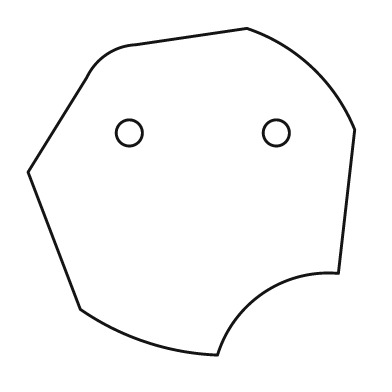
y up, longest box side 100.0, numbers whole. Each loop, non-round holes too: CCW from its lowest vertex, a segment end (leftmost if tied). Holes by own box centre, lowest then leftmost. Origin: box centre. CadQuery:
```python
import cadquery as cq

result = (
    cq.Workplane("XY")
    .moveTo(8.0, -50.0)
    .threePointArc((22.0, -31.0), (45.0, -25.0))
    .lineTo(50.0, 19.0)
    .threePointArc((37.0, 38.0), (17.0, 50.0))
    .lineTo(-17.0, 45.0)
    .threePointArc((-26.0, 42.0), (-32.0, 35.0))
    .lineTo(-50.0, 6.0)
    .lineTo(-34.0, -36.0)
    .threePointArc((-14.0, -46.0), (8.0, -50.0))
    .close()
    .moveTo(-19.0, 18.0)
    .circle(4.0)
    .moveTo(26.0, 18.0)
    .circle(4.0)
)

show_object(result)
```